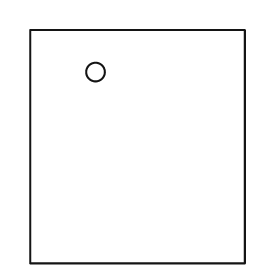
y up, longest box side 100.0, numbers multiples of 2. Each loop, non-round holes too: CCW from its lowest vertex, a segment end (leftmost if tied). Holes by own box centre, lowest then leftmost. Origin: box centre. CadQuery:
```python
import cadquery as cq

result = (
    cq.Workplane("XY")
    .moveTo(-46.0, -50.0)
    .lineTo(46.0, -50.0)
    .lineTo(46.0, 50.0)
    .lineTo(-46.0, 50.0)
    .close()
    .moveTo(-18.0, 32.0)
    .circle(4.0)
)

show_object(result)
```